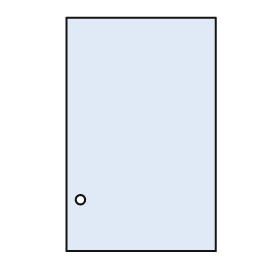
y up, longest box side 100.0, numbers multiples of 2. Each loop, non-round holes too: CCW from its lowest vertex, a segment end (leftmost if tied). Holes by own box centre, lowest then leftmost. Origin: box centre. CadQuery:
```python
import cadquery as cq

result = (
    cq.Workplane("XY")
    .moveTo(-32.0, -50.0)
    .lineTo(32.0, -50.0)
    .lineTo(32.0, 50.0)
    .lineTo(-32.0, 50.0)
    .close()
    .moveTo(-26.0, -28.0)
    .circle(2.0)
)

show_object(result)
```